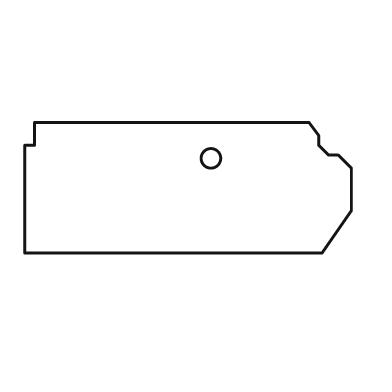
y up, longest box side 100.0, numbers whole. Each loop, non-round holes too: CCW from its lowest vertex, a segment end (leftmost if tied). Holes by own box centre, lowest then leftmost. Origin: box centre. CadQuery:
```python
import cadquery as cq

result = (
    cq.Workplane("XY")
    .moveTo(-50.0, -20.0)
    .lineTo(41.0, -20.0)
    .lineTo(50.0, -7.0)
    .lineTo(50.0, 6.0)
    .lineTo(46.0, 10.0)
    .lineTo(43.0, 10.0)
    .lineTo(40.0, 13.0)
    .lineTo(40.0, 16.0)
    .lineTo(37.0, 20.0)
    .lineTo(-47.0, 20.0)
    .lineTo(-47.0, 13.0)
    .lineTo(-50.0, 13.0)
    .close()
    .moveTo(7.0, 9.0)
    .circle(3.0)
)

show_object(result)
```